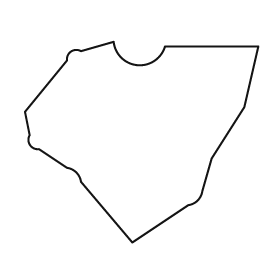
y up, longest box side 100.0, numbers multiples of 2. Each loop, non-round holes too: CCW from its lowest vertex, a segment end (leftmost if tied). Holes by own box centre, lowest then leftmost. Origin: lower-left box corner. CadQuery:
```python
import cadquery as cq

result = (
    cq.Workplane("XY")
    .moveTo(46.0, 0.0)
    .lineTo(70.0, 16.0)
    .threePointArc((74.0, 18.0), (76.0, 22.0))
    .lineTo(80.0, 36.0)
    .lineTo(94.0, 58.0)
    .lineTo(100.0, 84.0)
    .lineTo(60.0, 84.0)
    .threePointArc((48.0, 76.0), (38.0, 86.0))
    .lineTo(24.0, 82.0)
    .threePointArc((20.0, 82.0), (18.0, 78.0))
    .lineTo(0.0, 56.0)
    .lineTo(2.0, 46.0)
    .threePointArc((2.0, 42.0), (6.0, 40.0))
    .lineTo(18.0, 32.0)
    .threePointArc((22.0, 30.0), (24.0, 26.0))
    .close()
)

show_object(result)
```